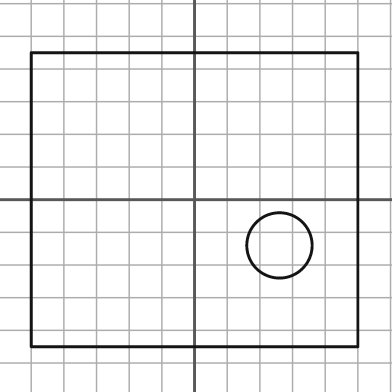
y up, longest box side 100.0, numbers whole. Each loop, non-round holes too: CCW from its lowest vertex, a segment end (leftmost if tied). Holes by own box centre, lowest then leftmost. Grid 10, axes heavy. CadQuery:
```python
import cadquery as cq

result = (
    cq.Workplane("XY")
    .moveTo(-50.0, -45.0)
    .lineTo(50.0, -45.0)
    .lineTo(50.0, 45.0)
    .lineTo(-50.0, 45.0)
    .close()
    .moveTo(26.0, -14.0)
    .circle(10.0)
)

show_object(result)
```